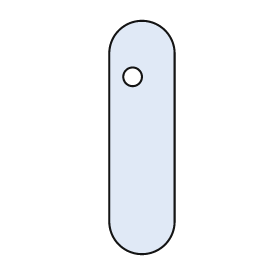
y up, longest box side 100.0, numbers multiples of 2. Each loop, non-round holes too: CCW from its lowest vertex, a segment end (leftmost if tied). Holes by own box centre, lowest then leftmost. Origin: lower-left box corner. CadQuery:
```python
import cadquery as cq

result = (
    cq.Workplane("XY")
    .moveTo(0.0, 14.0)
    .threePointArc((14.0, 0.0), (28.0, 14.0))
    .lineTo(28.0, 86.0)
    .threePointArc((14.0, 100.0), (0.0, 86.0))
    .close()
    .moveTo(10.0, 76.0)
    .circle(4.0)
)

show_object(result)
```